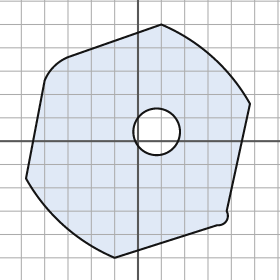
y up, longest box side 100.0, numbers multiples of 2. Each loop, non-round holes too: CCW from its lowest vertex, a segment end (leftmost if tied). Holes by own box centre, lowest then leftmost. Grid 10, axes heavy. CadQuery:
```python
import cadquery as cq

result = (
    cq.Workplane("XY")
    .moveTo(-10.0, -50.0)
    .lineTo(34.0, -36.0)
    .threePointArc((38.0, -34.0), (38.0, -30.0))
    .lineTo(48.0, 16.0)
    .threePointArc((32.0, 36.0), (10.0, 50.0))
    .lineTo(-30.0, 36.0)
    .threePointArc((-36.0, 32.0), (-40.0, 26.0))
    .lineTo(-48.0, -16.0)
    .threePointArc((-32.0, -36.0), (-10.0, -50.0))
    .close()
    .moveTo(8.0, 4.0)
    .circle(10.0)
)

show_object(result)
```